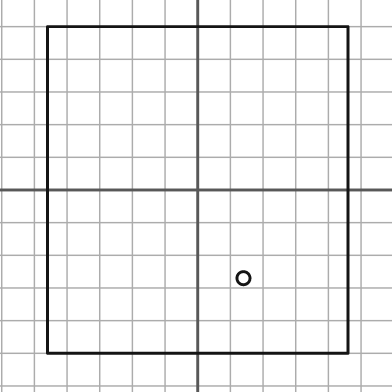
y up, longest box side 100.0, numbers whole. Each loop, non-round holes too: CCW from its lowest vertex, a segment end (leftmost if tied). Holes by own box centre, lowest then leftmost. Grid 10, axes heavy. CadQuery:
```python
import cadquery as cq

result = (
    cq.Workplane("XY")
    .moveTo(-46.0, -50.0)
    .lineTo(46.0, -50.0)
    .lineTo(46.0, 50.0)
    .lineTo(-46.0, 50.0)
    .close()
    .moveTo(14.0, -27.0)
    .circle(2.0)
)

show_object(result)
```